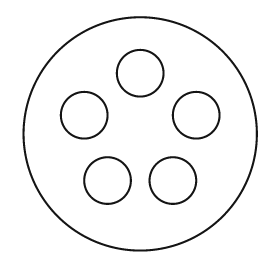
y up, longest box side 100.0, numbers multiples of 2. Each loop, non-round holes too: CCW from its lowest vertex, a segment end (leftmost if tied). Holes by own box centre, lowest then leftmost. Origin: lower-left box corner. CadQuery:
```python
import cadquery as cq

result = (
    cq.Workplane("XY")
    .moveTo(50.0, 50.0)
    .circle(50.0)
    .moveTo(36.0, 30.0)
    .circle(10.0)
    .moveTo(64.0, 30.0)
    .circle(10.0)
    .moveTo(26.0, 58.0)
    .circle(10.0)
    .moveTo(74.0, 58.0)
    .circle(10.0)
    .moveTo(50.0, 76.0)
    .circle(10.0)
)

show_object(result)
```